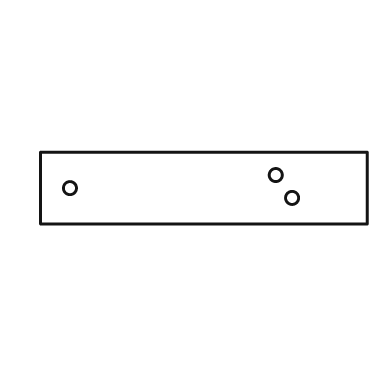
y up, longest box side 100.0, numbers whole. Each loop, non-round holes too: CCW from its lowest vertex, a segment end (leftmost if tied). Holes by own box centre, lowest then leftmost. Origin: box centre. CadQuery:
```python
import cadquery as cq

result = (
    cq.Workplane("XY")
    .moveTo(-50.0, -11.0)
    .lineTo(50.0, -11.0)
    .lineTo(50.0, 11.0)
    .lineTo(-50.0, 11.0)
    .close()
    .moveTo(27.0, -3.0)
    .circle(2.0)
    .moveTo(-41.0, 0.0)
    .circle(2.0)
    .moveTo(22.0, 4.0)
    .circle(2.0)
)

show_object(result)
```